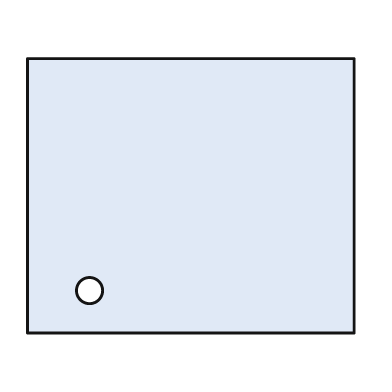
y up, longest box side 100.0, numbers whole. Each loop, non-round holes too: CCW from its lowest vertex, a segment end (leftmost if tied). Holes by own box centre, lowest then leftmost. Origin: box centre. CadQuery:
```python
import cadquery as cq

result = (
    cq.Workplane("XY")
    .moveTo(-50.0, -42.0)
    .lineTo(50.0, -42.0)
    .lineTo(50.0, 42.0)
    .lineTo(-50.0, 42.0)
    .close()
    .moveTo(-31.0, -29.0)
    .circle(4.0)
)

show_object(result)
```